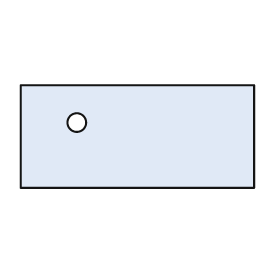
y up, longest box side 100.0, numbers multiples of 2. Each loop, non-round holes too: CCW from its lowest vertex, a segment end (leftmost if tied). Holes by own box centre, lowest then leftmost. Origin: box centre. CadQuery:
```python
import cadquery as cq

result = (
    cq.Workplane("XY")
    .moveTo(-50.0, -22.0)
    .lineTo(50.0, -22.0)
    .lineTo(50.0, 22.0)
    .lineTo(-50.0, 22.0)
    .close()
    .moveTo(-26.0, 6.0)
    .circle(4.0)
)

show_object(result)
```